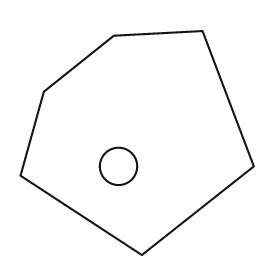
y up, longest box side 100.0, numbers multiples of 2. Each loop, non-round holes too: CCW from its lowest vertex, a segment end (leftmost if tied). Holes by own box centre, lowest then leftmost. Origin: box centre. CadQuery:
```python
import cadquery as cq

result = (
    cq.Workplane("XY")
    .moveTo(2.0, -48.0)
    .lineTo(50.0, -10.0)
    .lineTo(28.0, 48.0)
    .lineTo(-10.0, 46.0)
    .lineTo(-40.0, 22.0)
    .lineTo(-50.0, -14.0)
    .close()
    .moveTo(-8.0, -10.0)
    .circle(8.0)
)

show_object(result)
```